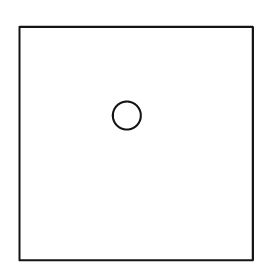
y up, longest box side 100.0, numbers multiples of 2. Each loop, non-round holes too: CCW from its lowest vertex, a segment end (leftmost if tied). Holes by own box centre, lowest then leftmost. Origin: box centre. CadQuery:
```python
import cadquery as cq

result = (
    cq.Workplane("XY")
    .moveTo(-50.0, -50.0)
    .lineTo(50.0, -50.0)
    .lineTo(50.0, 50.0)
    .lineTo(-50.0, 50.0)
    .close()
    .moveTo(-4.0, 12.0)
    .circle(6.0)
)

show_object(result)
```